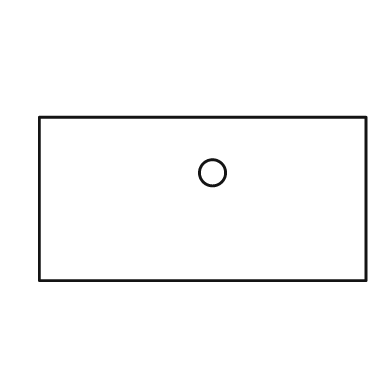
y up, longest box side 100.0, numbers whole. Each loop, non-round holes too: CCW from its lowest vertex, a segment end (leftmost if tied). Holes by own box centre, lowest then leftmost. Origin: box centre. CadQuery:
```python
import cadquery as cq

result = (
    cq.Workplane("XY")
    .moveTo(-50.0, -25.0)
    .lineTo(50.0, -25.0)
    .lineTo(50.0, 25.0)
    .lineTo(-50.0, 25.0)
    .close()
    .moveTo(3.0, 8.0)
    .circle(4.0)
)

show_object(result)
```